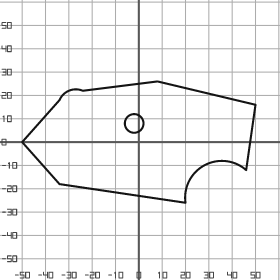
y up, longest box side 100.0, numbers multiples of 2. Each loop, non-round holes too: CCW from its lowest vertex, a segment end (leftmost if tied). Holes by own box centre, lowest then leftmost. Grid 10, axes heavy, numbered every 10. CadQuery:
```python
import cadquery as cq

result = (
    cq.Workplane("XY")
    .moveTo(20.0, -26.0)
    .threePointArc((28.0, -10.0), (46.0, -12.0))
    .lineTo(50.0, 16.0)
    .lineTo(8.0, 26.0)
    .lineTo(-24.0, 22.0)
    .threePointArc((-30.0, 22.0), (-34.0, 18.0))
    .lineTo(-50.0, 0.0)
    .lineTo(-34.0, -18.0)
    .close()
    .moveTo(-2.0, 8.0)
    .circle(4.0)
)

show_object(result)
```